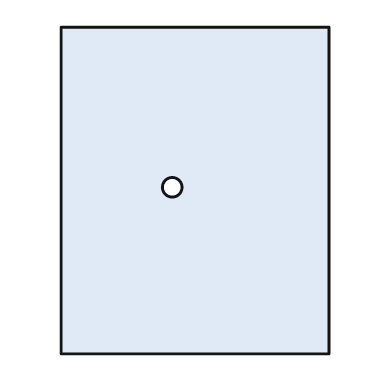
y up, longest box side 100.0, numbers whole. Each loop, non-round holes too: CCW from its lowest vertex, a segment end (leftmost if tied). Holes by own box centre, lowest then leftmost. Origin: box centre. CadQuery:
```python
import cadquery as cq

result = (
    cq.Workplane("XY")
    .moveTo(-41.0, -50.0)
    .lineTo(41.0, -50.0)
    .lineTo(41.0, 50.0)
    .lineTo(-41.0, 50.0)
    .close()
    .moveTo(-7.0, 1.0)
    .circle(3.0)
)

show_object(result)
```